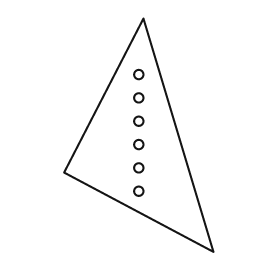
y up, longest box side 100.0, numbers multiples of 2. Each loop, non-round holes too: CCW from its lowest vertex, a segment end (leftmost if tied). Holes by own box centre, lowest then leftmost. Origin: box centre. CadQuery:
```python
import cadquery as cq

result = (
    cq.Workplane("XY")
    .moveTo(32.0, -50.0)
    .lineTo(2.0, 50.0)
    .lineTo(-32.0, -16.0)
    .close()
    .moveTo(0.0, -24.0)
    .circle(2.0)
    .moveTo(0.0, -14.0)
    .circle(2.0)
    .moveTo(0.0, -4.0)
    .circle(2.0)
    .moveTo(0.0, 6.0)
    .circle(2.0)
    .moveTo(0.0, 16.0)
    .circle(2.0)
    .moveTo(0.0, 26.0)
    .circle(2.0)
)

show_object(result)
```